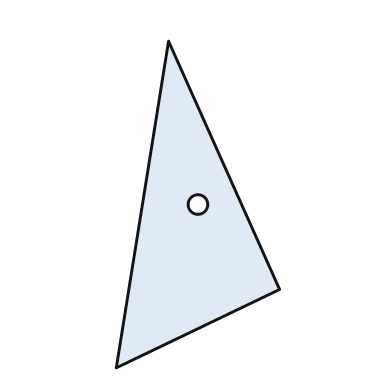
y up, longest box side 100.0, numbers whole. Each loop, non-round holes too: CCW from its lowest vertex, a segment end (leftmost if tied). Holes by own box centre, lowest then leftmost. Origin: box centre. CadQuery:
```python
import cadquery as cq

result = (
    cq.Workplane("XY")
    .moveTo(-25.0, -50.0)
    .lineTo(25.0, -26.0)
    .lineTo(-9.0, 50.0)
    .close()
    .moveTo(0.0, 0.0)
    .circle(3.0)
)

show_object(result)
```